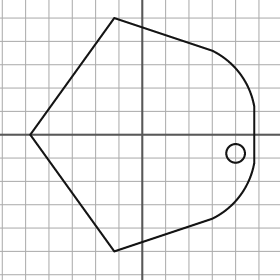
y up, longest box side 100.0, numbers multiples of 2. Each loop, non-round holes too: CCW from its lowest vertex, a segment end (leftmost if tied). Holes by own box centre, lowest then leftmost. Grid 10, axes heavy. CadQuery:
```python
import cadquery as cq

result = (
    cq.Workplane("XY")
    .moveTo(-12.0, -50.0)
    .lineTo(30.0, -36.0)
    .threePointArc((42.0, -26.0), (48.0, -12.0))
    .lineTo(48.0, 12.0)
    .threePointArc((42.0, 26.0), (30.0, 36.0))
    .lineTo(-12.0, 50.0)
    .lineTo(-48.0, 0.0)
    .close()
    .moveTo(40.0, -8.0)
    .circle(4.0)
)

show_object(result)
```